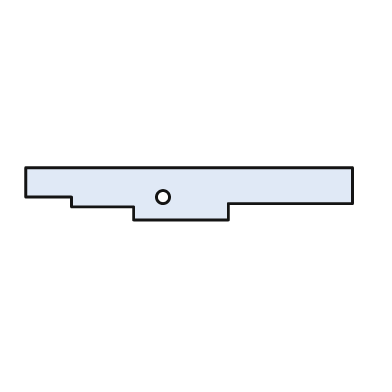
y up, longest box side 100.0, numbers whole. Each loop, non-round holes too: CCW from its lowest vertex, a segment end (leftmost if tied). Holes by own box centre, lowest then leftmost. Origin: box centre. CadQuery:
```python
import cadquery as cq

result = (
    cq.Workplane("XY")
    .moveTo(-17.0, -8.0)
    .lineTo(12.0, -8.0)
    .lineTo(12.0, -3.0)
    .lineTo(50.0, -3.0)
    .lineTo(50.0, 8.0)
    .lineTo(-50.0, 8.0)
    .lineTo(-50.0, -1.0)
    .lineTo(-36.0, -1.0)
    .lineTo(-36.0, -4.0)
    .lineTo(-17.0, -4.0)
    .close()
    .moveTo(-8.0, -1.0)
    .circle(2.0)
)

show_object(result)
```